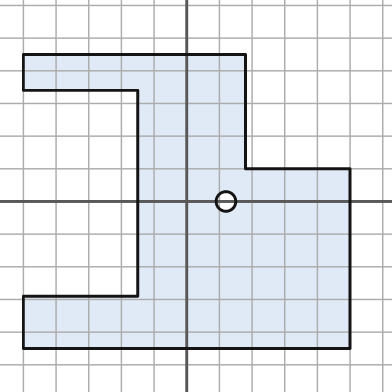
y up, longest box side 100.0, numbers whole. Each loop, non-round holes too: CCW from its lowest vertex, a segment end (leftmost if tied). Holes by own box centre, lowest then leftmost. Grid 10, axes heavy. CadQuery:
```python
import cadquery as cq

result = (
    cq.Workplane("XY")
    .moveTo(-50.0, -45.0)
    .lineTo(50.0, -45.0)
    .lineTo(50.0, 10.0)
    .lineTo(18.0, 10.0)
    .lineTo(18.0, 45.0)
    .lineTo(-50.0, 45.0)
    .lineTo(-50.0, 34.0)
    .lineTo(-15.0, 34.0)
    .lineTo(-15.0, -29.0)
    .lineTo(-50.0, -29.0)
    .close()
    .moveTo(12.0, 0.0)
    .circle(3.0)
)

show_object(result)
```